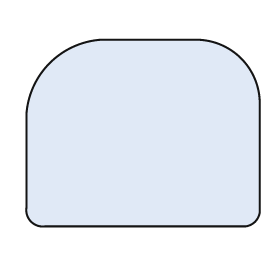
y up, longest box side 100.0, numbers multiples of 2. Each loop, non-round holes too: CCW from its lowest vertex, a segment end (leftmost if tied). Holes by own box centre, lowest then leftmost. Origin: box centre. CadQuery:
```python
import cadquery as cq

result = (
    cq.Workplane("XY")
    .moveTo(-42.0, -40.0)
    .lineTo(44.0, -40.0)
    .threePointArc((48.0, -38.0), (50.0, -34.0))
    .lineTo(50.0, 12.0)
    .threePointArc((42.0, 32.0), (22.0, 40.0))
    .lineTo(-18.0, 40.0)
    .threePointArc((-40.0, 30.0), (-50.0, 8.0))
    .lineTo(-50.0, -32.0)
    .threePointArc((-48.0, -38.0), (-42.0, -40.0))
    .close()
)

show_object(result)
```